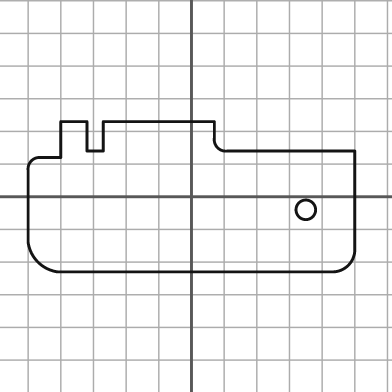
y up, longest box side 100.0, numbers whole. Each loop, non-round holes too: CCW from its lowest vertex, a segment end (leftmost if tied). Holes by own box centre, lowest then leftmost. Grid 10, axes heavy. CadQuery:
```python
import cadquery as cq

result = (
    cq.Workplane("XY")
    .moveTo(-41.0, -23.0)
    .lineTo(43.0, -23.0)
    .threePointArc((48.0, -21.0), (50.0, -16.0))
    .lineTo(50.0, 14.0)
    .lineTo(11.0, 14.0)
    .threePointArc((8.0, 15.0), (7.0, 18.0))
    .lineTo(7.0, 23.0)
    .lineTo(-27.0, 23.0)
    .lineTo(-27.0, 14.0)
    .lineTo(-32.0, 14.0)
    .lineTo(-32.0, 23.0)
    .lineTo(-40.0, 23.0)
    .lineTo(-40.0, 12.0)
    .lineTo(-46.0, 12.0)
    .threePointArc((-49.0, 11.0), (-50.0, 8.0))
    .lineTo(-50.0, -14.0)
    .threePointArc((-47.0, -20.0), (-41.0, -23.0))
    .close()
    .moveTo(35.0, -4.0)
    .circle(3.0)
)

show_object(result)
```